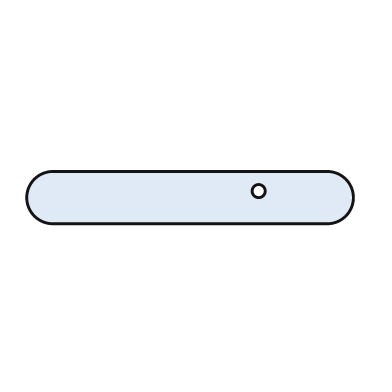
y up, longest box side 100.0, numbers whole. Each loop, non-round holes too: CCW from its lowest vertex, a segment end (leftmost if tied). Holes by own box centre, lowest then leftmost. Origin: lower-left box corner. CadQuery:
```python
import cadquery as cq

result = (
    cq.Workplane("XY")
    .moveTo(8.0, 0.0)
    .lineTo(92.0, 0.0)
    .threePointArc((100.0, 8.0), (92.0, 16.0))
    .lineTo(8.0, 16.0)
    .threePointArc((0.0, 8.0), (8.0, 0.0))
    .close()
    .moveTo(71.0, 10.0)
    .circle(2.0)
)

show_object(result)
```